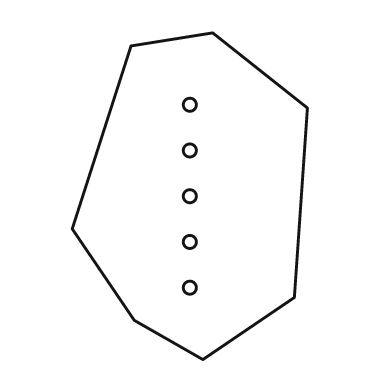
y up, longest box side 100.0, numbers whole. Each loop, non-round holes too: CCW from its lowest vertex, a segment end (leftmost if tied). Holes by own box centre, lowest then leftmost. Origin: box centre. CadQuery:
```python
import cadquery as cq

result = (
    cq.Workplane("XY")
    .moveTo(4.0, -50.0)
    .lineTo(32.0, -31.0)
    .lineTo(36.0, 27.0)
    .lineTo(7.0, 50.0)
    .lineTo(-18.0, 46.0)
    .lineTo(-36.0, -10.0)
    .lineTo(-17.0, -38.0)
    .close()
    .moveTo(0.0, -28.0)
    .circle(2.0)
    .moveTo(0.0, -14.0)
    .circle(2.0)
    .moveTo(0.0, 0.0)
    .circle(2.0)
    .moveTo(0.0, 14.0)
    .circle(2.0)
    .moveTo(0.0, 28.0)
    .circle(2.0)
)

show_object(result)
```